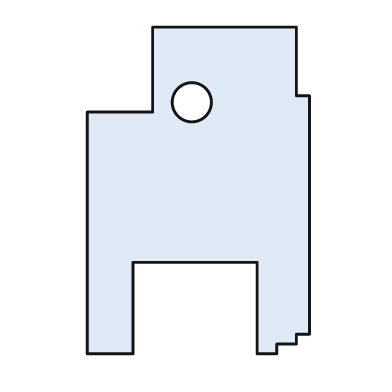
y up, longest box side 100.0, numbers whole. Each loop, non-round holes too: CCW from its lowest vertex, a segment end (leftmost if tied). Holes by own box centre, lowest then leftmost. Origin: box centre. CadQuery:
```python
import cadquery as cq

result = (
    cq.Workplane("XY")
    .moveTo(-34.0, -50.0)
    .lineTo(-20.0, -50.0)
    .lineTo(-20.0, -22.0)
    .lineTo(18.0, -22.0)
    .lineTo(18.0, -50.0)
    .lineTo(24.0, -50.0)
    .lineTo(24.0, -47.0)
    .lineTo(30.0, -47.0)
    .lineTo(30.0, -44.0)
    .lineTo(34.0, -44.0)
    .lineTo(34.0, 29.0)
    .lineTo(30.0, 29.0)
    .lineTo(30.0, 50.0)
    .lineTo(-14.0, 50.0)
    .lineTo(-14.0, 24.0)
    .lineTo(-34.0, 24.0)
    .close()
    .moveTo(-2.0, 27.0)
    .circle(6.0)
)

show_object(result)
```